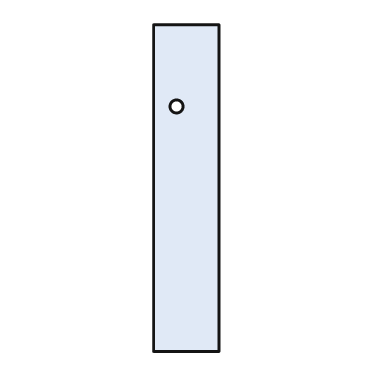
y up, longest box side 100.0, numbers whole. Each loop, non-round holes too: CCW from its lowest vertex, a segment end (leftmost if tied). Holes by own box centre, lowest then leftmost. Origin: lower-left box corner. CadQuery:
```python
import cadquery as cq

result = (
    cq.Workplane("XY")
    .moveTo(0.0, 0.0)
    .lineTo(20.0, 0.0)
    .lineTo(20.0, 100.0)
    .lineTo(0.0, 100.0)
    .close()
    .moveTo(7.0, 75.0)
    .circle(2.0)
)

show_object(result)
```